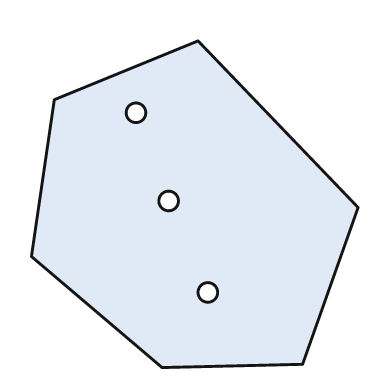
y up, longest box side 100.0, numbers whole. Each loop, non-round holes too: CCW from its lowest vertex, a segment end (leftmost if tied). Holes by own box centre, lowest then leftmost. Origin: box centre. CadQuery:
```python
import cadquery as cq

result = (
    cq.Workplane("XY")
    .moveTo(-10.0, -50.0)
    .lineTo(33.0, -49.0)
    .lineTo(50.0, -1.0)
    .lineTo(1.0, 50.0)
    .lineTo(-43.0, 32.0)
    .lineTo(-50.0, -16.0)
    .close()
    .moveTo(4.0, -27.0)
    .circle(3.0)
    .moveTo(-8.0, 1.0)
    .circle(3.0)
    .moveTo(-18.0, 28.0)
    .circle(3.0)
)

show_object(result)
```